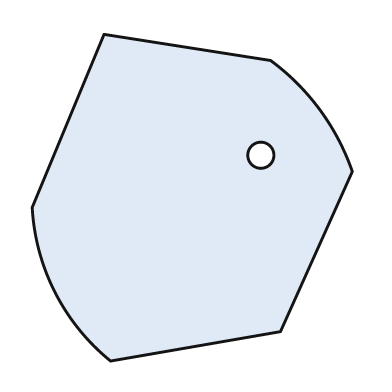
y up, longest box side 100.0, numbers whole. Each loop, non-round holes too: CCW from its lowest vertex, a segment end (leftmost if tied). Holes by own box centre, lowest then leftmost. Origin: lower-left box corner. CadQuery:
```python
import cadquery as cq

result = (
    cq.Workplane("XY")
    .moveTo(24.0, 0.0)
    .lineTo(76.0, 9.0)
    .lineTo(98.0, 58.0)
    .threePointArc((88.0, 77.0), (73.0, 92.0))
    .lineTo(22.0, 100.0)
    .lineTo(0.0, 47.0)
    .threePointArc((7.0, 21.0), (24.0, 0.0))
    .close()
    .moveTo(70.0, 63.0)
    .circle(4.0)
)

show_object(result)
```